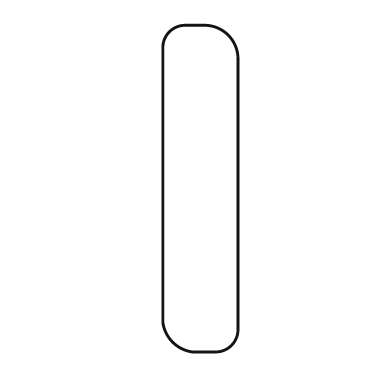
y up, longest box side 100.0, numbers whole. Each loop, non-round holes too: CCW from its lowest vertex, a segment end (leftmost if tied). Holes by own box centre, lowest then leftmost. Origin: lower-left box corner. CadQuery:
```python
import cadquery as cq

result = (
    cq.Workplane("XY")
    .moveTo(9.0, 0.0)
    .lineTo(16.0, 0.0)
    .threePointArc((21.0, 2.0), (23.0, 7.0))
    .lineTo(23.0, 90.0)
    .threePointArc((20.0, 97.0), (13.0, 100.0))
    .lineTo(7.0, 100.0)
    .threePointArc((2.0, 98.0), (0.0, 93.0))
    .lineTo(0.0, 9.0)
    .threePointArc((3.0, 3.0), (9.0, 0.0))
    .close()
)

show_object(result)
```